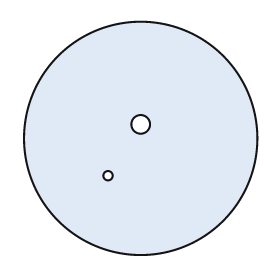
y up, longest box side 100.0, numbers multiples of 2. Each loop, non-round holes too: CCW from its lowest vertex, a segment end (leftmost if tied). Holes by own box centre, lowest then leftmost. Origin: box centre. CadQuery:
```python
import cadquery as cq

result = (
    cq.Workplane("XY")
    .moveTo(0.0, 0.0)
    .circle(50.0)
    .moveTo(-14.0, -16.0)
    .circle(2.0)
    .moveTo(0.0, 6.0)
    .circle(4.0)
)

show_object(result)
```